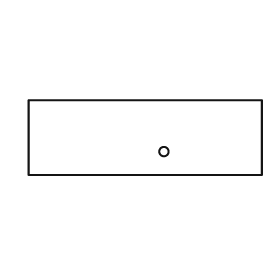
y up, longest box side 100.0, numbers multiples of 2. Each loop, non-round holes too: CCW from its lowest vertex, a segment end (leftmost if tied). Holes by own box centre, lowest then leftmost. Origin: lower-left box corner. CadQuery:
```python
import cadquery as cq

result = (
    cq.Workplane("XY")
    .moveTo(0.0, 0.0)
    .lineTo(100.0, 0.0)
    .lineTo(100.0, 32.0)
    .lineTo(0.0, 32.0)
    .close()
    .moveTo(58.0, 10.0)
    .circle(2.0)
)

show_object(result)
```